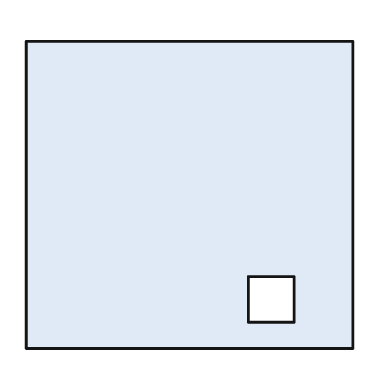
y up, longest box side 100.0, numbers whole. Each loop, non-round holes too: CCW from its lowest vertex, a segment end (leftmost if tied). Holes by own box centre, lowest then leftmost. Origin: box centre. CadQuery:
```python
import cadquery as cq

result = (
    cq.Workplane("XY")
    .moveTo(-50.0, -47.0)
    .lineTo(50.0, -47.0)
    .lineTo(50.0, 47.0)
    .lineTo(-50.0, 47.0)
    .close()
    .moveTo(18.0, -39.0)
    .lineTo(32.0, -39.0)
    .lineTo(32.0, -25.0)
    .lineTo(18.0, -25.0)
    .close()
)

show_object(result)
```